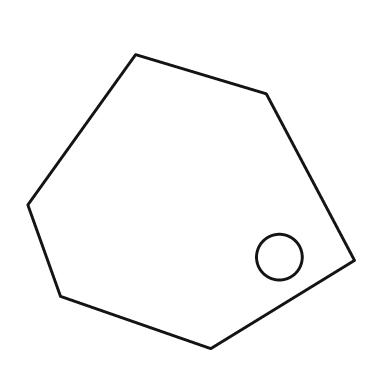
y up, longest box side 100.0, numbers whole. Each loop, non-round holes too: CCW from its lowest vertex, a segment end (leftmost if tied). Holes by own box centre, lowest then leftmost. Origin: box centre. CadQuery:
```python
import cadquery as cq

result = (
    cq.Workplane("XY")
    .moveTo(6.0, -45.0)
    .lineTo(50.0, -18.0)
    .lineTo(23.0, 33.0)
    .lineTo(-17.0, 45.0)
    .lineTo(-50.0, -1.0)
    .lineTo(-40.0, -29.0)
    .close()
    .moveTo(27.0, -17.0)
    .circle(7.0)
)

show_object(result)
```